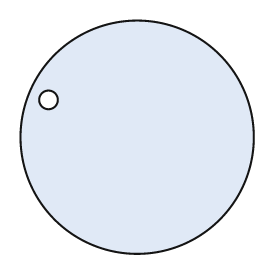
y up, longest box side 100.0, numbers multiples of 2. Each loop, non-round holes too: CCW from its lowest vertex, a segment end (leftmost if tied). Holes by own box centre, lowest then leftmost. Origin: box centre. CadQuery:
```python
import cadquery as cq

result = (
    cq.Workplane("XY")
    .moveTo(0.0, 0.0)
    .circle(50.0)
    .moveTo(-38.0, 16.0)
    .circle(4.0)
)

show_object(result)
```